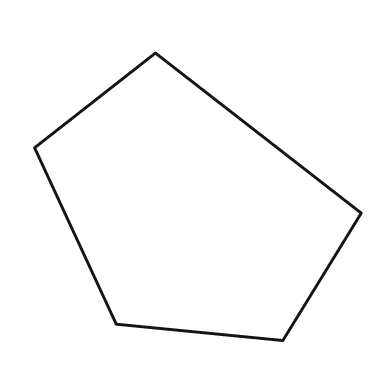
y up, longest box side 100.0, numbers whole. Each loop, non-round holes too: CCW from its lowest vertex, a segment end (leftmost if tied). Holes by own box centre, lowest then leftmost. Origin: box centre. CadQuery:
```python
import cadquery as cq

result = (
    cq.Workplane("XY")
    .moveTo(26.0, -44.0)
    .lineTo(50.0, -5.0)
    .lineTo(-13.0, 44.0)
    .lineTo(-50.0, 15.0)
    .lineTo(-25.0, -39.0)
    .close()
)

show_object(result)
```